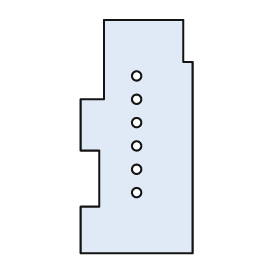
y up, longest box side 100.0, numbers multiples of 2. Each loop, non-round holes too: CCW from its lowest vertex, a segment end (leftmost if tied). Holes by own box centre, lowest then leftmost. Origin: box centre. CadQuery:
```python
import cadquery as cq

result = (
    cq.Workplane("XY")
    .moveTo(-24.0, -50.0)
    .lineTo(24.0, -50.0)
    .lineTo(24.0, 32.0)
    .lineTo(20.0, 32.0)
    .lineTo(20.0, 50.0)
    .lineTo(-14.0, 50.0)
    .lineTo(-14.0, 16.0)
    .lineTo(-24.0, 16.0)
    .lineTo(-24.0, -6.0)
    .lineTo(-16.0, -6.0)
    .lineTo(-16.0, -30.0)
    .lineTo(-24.0, -30.0)
    .close()
    .moveTo(0.0, -24.0)
    .circle(2.0)
    .moveTo(0.0, -14.0)
    .circle(2.0)
    .moveTo(0.0, -4.0)
    .circle(2.0)
    .moveTo(0.0, 6.0)
    .circle(2.0)
    .moveTo(0.0, 16.0)
    .circle(2.0)
    .moveTo(0.0, 26.0)
    .circle(2.0)
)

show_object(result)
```